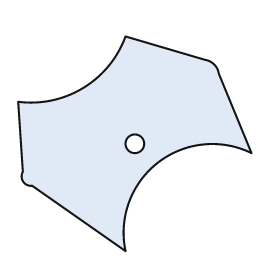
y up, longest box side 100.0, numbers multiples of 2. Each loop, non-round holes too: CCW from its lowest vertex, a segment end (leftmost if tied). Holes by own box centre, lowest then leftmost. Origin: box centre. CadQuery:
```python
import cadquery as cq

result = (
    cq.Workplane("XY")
    .moveTo(-4.0, -46.0)
    .threePointArc((10.0, -8.0), (50.0, -4.0))
    .lineTo(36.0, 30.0)
    .threePointArc((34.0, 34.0), (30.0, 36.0))
    .lineTo(-4.0, 46.0)
    .threePointArc((-22.0, 24.0), (-50.0, 18.0))
    .lineTo(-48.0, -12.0)
    .threePointArc((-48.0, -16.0), (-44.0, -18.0))
    .close()
    .moveTo(0.0, 0.0)
    .circle(4.0)
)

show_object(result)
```